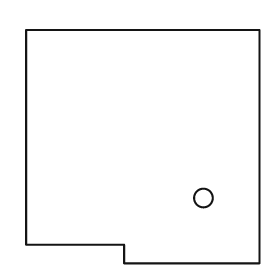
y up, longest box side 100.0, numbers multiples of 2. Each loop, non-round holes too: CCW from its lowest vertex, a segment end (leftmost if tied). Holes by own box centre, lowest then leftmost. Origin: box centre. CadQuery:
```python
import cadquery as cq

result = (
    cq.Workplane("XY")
    .moveTo(-8.0, -50.0)
    .lineTo(50.0, -50.0)
    .lineTo(50.0, 50.0)
    .lineTo(-50.0, 50.0)
    .lineTo(-50.0, -42.0)
    .lineTo(-8.0, -42.0)
    .close()
    .moveTo(26.0, -22.0)
    .circle(4.0)
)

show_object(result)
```